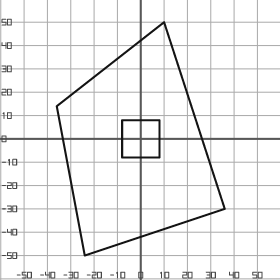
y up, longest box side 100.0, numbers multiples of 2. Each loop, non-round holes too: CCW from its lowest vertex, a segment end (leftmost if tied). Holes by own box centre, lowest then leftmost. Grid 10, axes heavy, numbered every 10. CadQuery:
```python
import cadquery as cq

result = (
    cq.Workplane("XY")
    .moveTo(-24.0, -50.0)
    .lineTo(36.0, -30.0)
    .lineTo(10.0, 50.0)
    .lineTo(-36.0, 14.0)
    .close()
    .moveTo(-8.0, -8.0)
    .lineTo(8.0, -8.0)
    .lineTo(8.0, 8.0)
    .lineTo(-8.0, 8.0)
    .close()
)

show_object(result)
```